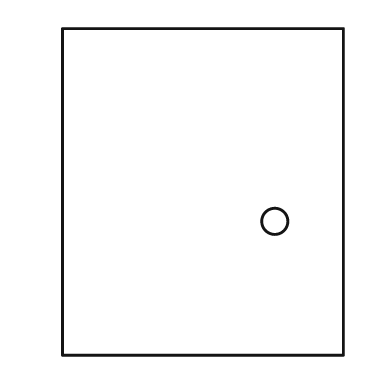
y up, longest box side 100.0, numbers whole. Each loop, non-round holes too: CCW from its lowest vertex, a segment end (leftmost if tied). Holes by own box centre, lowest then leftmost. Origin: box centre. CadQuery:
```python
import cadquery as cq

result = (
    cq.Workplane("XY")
    .moveTo(-43.0, -50.0)
    .lineTo(43.0, -50.0)
    .lineTo(43.0, 50.0)
    .lineTo(-43.0, 50.0)
    .close()
    .moveTo(22.0, -9.0)
    .circle(4.0)
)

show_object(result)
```